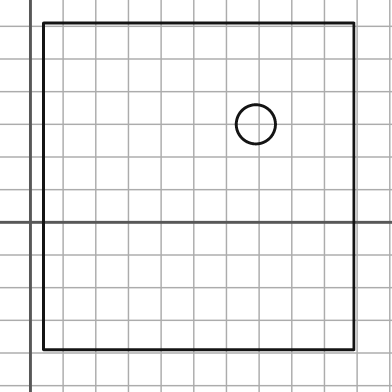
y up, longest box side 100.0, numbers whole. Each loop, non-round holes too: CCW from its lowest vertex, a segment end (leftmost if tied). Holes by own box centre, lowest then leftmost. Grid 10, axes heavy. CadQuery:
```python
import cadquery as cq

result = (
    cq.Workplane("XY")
    .moveTo(4.0, -39.0)
    .lineTo(99.0, -39.0)
    .lineTo(99.0, 61.0)
    .lineTo(4.0, 61.0)
    .close()
    .moveTo(69.0, 30.0)
    .circle(6.0)
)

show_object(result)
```